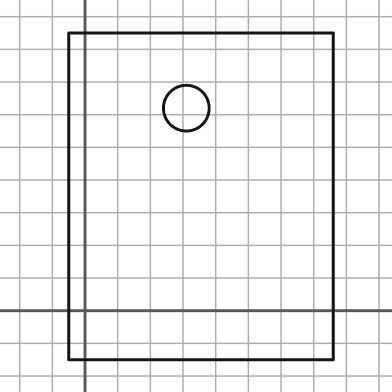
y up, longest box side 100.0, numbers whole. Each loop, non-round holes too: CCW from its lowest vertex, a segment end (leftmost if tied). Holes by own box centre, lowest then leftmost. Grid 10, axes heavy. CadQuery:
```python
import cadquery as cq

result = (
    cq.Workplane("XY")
    .moveTo(-5.0, -15.0)
    .lineTo(76.0, -15.0)
    .lineTo(76.0, 85.0)
    .lineTo(-5.0, 85.0)
    .close()
    .moveTo(31.0, 62.0)
    .circle(7.0)
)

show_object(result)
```